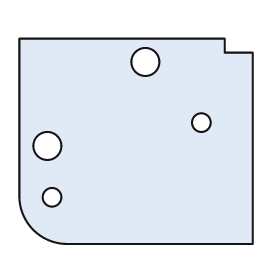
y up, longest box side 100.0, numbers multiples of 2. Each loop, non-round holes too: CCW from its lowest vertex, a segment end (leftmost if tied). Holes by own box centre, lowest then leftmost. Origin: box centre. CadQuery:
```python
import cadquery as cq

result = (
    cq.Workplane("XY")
    .moveTo(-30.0, -44.0)
    .lineTo(50.0, -44.0)
    .lineTo(50.0, 38.0)
    .lineTo(38.0, 38.0)
    .lineTo(38.0, 44.0)
    .lineTo(-50.0, 44.0)
    .lineTo(-50.0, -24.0)
    .threePointArc((-44.0, -38.0), (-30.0, -44.0))
    .close()
    .moveTo(-36.0, -24.0)
    .circle(4.0)
    .moveTo(-38.0, -2.0)
    .circle(6.0)
    .moveTo(28.0, 8.0)
    .circle(4.0)
    .moveTo(4.0, 34.0)
    .circle(6.0)
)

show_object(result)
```